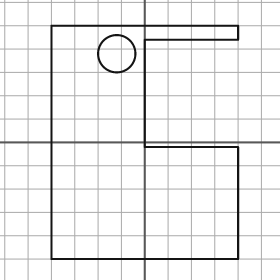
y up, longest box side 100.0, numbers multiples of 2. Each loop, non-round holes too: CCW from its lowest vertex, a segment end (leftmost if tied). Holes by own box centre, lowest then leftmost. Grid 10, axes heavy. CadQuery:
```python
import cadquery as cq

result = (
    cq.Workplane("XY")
    .moveTo(-40.0, -50.0)
    .lineTo(40.0, -50.0)
    .lineTo(40.0, -2.0)
    .lineTo(0.0, -2.0)
    .lineTo(0.0, 44.0)
    .lineTo(40.0, 44.0)
    .lineTo(40.0, 50.0)
    .lineTo(-40.0, 50.0)
    .close()
    .moveTo(-12.0, 38.0)
    .circle(8.0)
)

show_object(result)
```